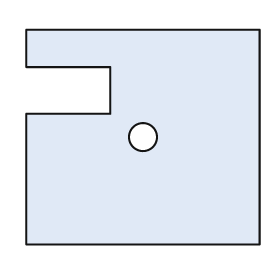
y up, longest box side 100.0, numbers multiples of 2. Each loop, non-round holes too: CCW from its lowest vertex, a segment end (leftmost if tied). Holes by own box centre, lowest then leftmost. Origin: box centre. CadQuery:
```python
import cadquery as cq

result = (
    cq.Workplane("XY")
    .moveTo(-50.0, -46.0)
    .lineTo(50.0, -46.0)
    .lineTo(50.0, 46.0)
    .lineTo(-50.0, 46.0)
    .lineTo(-50.0, 30.0)
    .lineTo(-14.0, 30.0)
    .lineTo(-14.0, 10.0)
    .lineTo(-50.0, 10.0)
    .close()
    .moveTo(0.0, 0.0)
    .circle(6.0)
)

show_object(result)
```